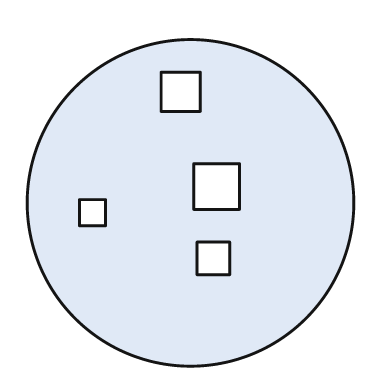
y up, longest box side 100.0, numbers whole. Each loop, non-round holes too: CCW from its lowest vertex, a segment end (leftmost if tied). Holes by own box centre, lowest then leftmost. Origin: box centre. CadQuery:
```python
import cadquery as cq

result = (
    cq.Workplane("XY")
    .moveTo(0.0, 0.0)
    .circle(50.0)
    .moveTo(2.0, -22.0)
    .lineTo(12.0, -22.0)
    .lineTo(12.0, -12.0)
    .lineTo(2.0, -12.0)
    .close()
    .moveTo(-34.0, -7.0)
    .lineTo(-26.0, -7.0)
    .lineTo(-26.0, 1.0)
    .lineTo(-34.0, 1.0)
    .close()
    .moveTo(1.0, -2.0)
    .lineTo(15.0, -2.0)
    .lineTo(15.0, 12.0)
    .lineTo(1.0, 12.0)
    .close()
    .moveTo(-9.0, 28.0)
    .lineTo(3.0, 28.0)
    .lineTo(3.0, 40.0)
    .lineTo(-9.0, 40.0)
    .close()
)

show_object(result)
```